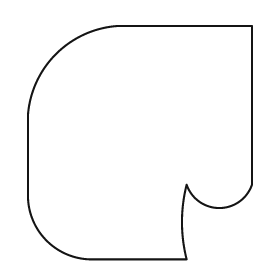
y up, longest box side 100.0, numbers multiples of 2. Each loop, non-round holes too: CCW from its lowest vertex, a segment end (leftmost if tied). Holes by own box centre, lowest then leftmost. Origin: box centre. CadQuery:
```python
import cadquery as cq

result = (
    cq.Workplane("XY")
    .moveTo(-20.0, -50.0)
    .lineTo(20.0, -50.0)
    .threePointArc((18.0, -34.0), (20.0, -18.0))
    .threePointArc((34.0, -28.0), (48.0, -18.0))
    .lineTo(48.0, 50.0)
    .lineTo(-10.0, 50.0)
    .threePointArc((-36.0, 38.0), (-48.0, 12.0))
    .lineTo(-48.0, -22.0)
    .threePointArc((-40.0, -42.0), (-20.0, -50.0))
    .close()
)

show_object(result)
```